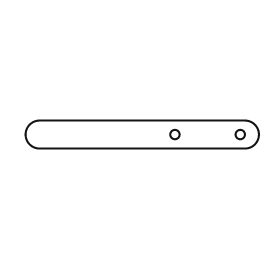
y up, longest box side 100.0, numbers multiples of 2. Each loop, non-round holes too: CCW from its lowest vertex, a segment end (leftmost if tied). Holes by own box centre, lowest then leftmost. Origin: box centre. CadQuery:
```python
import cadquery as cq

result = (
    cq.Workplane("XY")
    .moveTo(-44.0, -6.0)
    .lineTo(44.0, -6.0)
    .threePointArc((50.0, 0.0), (44.0, 6.0))
    .lineTo(-44.0, 6.0)
    .threePointArc((-50.0, 0.0), (-44.0, -6.0))
    .close()
    .moveTo(14.0, 0.0)
    .circle(2.0)
    .moveTo(42.0, 0.0)
    .circle(2.0)
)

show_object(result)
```